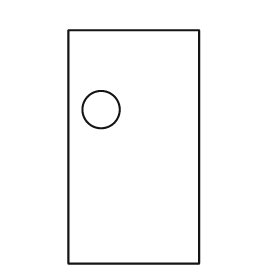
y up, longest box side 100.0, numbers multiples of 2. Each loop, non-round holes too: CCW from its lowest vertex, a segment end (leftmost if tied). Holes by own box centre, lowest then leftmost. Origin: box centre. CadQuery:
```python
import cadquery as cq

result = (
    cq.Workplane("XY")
    .moveTo(-28.0, -50.0)
    .lineTo(28.0, -50.0)
    .lineTo(28.0, 50.0)
    .lineTo(-28.0, 50.0)
    .close()
    .moveTo(-14.0, 16.0)
    .circle(8.0)
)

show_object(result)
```